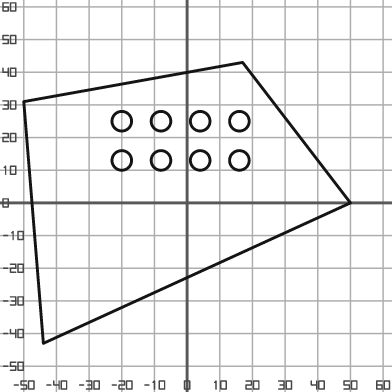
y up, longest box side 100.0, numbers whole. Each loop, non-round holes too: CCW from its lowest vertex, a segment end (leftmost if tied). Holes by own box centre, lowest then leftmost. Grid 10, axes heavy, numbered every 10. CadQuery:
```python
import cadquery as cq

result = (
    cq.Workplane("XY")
    .moveTo(-44.0, -43.0)
    .lineTo(50.0, 0.0)
    .lineTo(17.0, 43.0)
    .lineTo(-50.0, 31.0)
    .close()
    .moveTo(-20.0, 13.0)
    .circle(3.0)
    .moveTo(-8.0, 13.0)
    .circle(3.0)
    .moveTo(4.0, 13.0)
    .circle(3.0)
    .moveTo(16.0, 13.0)
    .circle(3.0)
    .moveTo(-20.0, 25.0)
    .circle(3.0)
    .moveTo(-8.0, 25.0)
    .circle(3.0)
    .moveTo(4.0, 25.0)
    .circle(3.0)
    .moveTo(16.0, 25.0)
    .circle(3.0)
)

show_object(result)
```